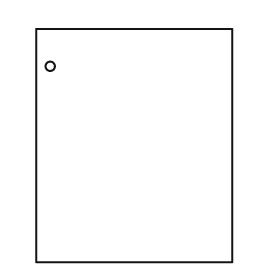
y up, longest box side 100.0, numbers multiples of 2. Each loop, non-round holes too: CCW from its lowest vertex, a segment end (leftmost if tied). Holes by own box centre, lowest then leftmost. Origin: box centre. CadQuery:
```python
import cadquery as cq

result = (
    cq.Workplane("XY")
    .moveTo(-42.0, -50.0)
    .lineTo(42.0, -50.0)
    .lineTo(42.0, 50.0)
    .lineTo(-42.0, 50.0)
    .close()
    .moveTo(-36.0, 34.0)
    .circle(2.0)
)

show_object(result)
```